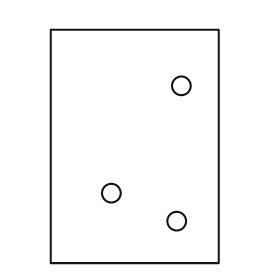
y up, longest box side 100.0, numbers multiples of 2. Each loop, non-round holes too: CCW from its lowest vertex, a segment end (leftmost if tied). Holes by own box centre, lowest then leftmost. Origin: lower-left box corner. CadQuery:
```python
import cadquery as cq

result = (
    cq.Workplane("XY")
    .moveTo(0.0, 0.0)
    .lineTo(72.0, 0.0)
    .lineTo(72.0, 100.0)
    .lineTo(0.0, 100.0)
    .close()
    .moveTo(54.0, 18.0)
    .circle(4.0)
    .moveTo(26.0, 30.0)
    .circle(4.0)
    .moveTo(56.0, 76.0)
    .circle(4.0)
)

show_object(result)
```